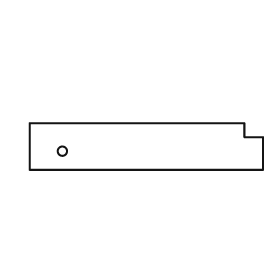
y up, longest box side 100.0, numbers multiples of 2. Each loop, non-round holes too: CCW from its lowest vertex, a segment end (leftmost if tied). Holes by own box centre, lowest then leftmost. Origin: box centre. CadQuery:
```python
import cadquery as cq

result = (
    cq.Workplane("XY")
    .moveTo(-50.0, -10.0)
    .lineTo(50.0, -10.0)
    .lineTo(50.0, 4.0)
    .lineTo(42.0, 4.0)
    .lineTo(42.0, 10.0)
    .lineTo(-50.0, 10.0)
    .close()
    .moveTo(-36.0, -2.0)
    .circle(2.0)
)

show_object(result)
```